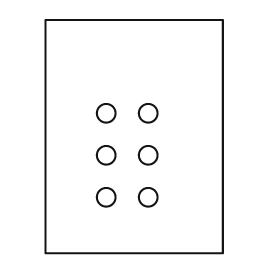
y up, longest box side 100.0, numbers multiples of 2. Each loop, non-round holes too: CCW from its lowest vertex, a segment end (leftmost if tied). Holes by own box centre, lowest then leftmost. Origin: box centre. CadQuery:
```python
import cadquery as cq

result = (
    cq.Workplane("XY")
    .moveTo(-38.0, -50.0)
    .lineTo(38.0, -50.0)
    .lineTo(38.0, 50.0)
    .lineTo(-38.0, 50.0)
    .close()
    .moveTo(-12.0, -26.0)
    .circle(4.0)
    .moveTo(6.0, -26.0)
    .circle(4.0)
    .moveTo(-12.0, -8.0)
    .circle(4.0)
    .moveTo(6.0, -8.0)
    .circle(4.0)
    .moveTo(-12.0, 10.0)
    .circle(4.0)
    .moveTo(6.0, 10.0)
    .circle(4.0)
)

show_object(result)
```